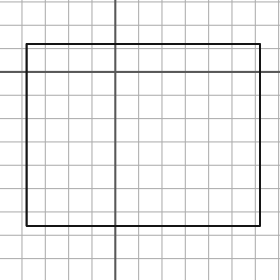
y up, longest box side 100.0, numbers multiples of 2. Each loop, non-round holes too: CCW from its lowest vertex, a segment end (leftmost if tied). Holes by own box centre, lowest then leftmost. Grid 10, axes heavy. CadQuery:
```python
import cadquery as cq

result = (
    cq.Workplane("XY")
    .moveTo(-38.0, -66.0)
    .lineTo(62.0, -66.0)
    .lineTo(62.0, 12.0)
    .lineTo(-38.0, 12.0)
    .close()
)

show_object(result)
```